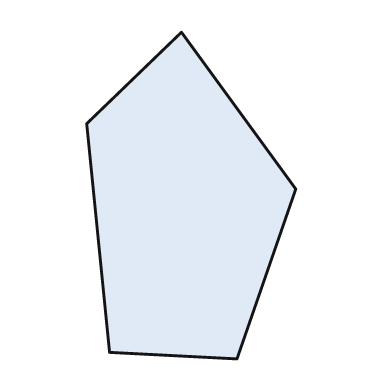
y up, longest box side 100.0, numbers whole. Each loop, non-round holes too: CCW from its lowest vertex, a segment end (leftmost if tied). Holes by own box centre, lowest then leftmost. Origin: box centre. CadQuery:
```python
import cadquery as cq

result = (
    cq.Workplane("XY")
    .moveTo(14.0, -50.0)
    .lineTo(32.0, 2.0)
    .lineTo(-3.0, 50.0)
    .lineTo(-32.0, 22.0)
    .lineTo(-25.0, -48.0)
    .close()
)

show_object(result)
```